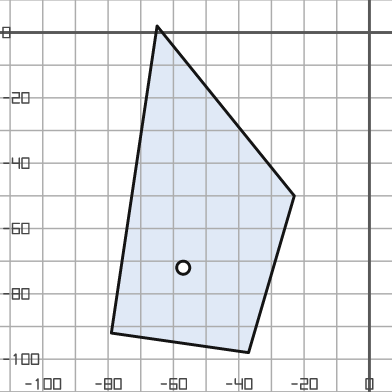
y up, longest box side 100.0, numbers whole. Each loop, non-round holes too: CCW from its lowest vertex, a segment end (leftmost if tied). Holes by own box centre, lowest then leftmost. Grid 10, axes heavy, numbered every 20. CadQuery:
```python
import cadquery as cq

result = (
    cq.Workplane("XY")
    .moveTo(-37.0, -98.0)
    .lineTo(-23.0, -50.0)
    .lineTo(-65.0, 2.0)
    .lineTo(-79.0, -92.0)
    .close()
    .moveTo(-57.0, -72.0)
    .circle(2.0)
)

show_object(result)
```